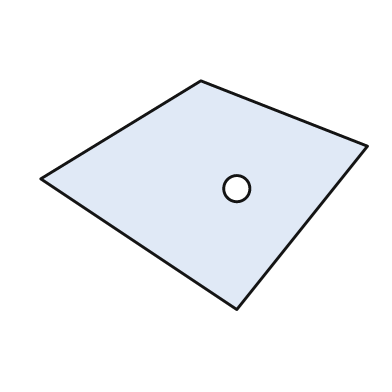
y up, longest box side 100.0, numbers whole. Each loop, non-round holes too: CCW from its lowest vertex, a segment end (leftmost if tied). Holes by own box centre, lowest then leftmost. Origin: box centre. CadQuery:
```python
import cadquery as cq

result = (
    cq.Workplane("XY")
    .moveTo(10.0, -35.0)
    .lineTo(50.0, 15.0)
    .lineTo(-1.0, 35.0)
    .lineTo(-50.0, 5.0)
    .close()
    .moveTo(10.0, 2.0)
    .circle(4.0)
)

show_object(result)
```